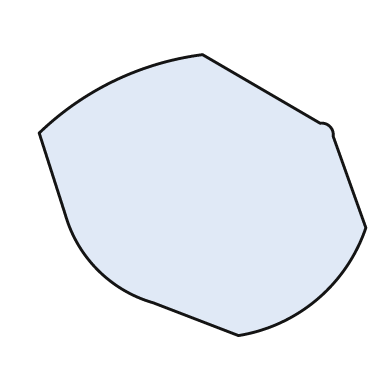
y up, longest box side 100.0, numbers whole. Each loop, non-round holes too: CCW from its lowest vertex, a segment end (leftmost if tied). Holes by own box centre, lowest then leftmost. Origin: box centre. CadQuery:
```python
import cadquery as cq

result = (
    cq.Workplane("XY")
    .moveTo(11.0, -43.0)
    .threePointArc((35.0, -32.0), (50.0, -10.0))
    .lineTo(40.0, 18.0)
    .threePointArc((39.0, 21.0), (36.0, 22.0))
    .lineTo(0.0, 43.0)
    .threePointArc((-27.0, 35.0), (-50.0, 19.0))
    .lineTo(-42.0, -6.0)
    .threePointArc((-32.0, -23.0), (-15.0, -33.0))
    .close()
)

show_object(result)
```